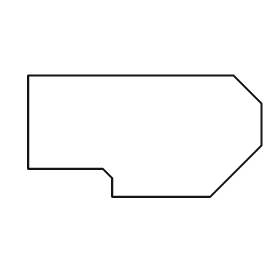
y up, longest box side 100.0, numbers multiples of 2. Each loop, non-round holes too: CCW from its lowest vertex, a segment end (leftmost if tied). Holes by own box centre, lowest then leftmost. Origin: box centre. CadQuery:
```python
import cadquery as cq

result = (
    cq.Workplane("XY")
    .moveTo(-14.0, -26.0)
    .lineTo(28.0, -26.0)
    .lineTo(50.0, -4.0)
    .lineTo(50.0, 14.0)
    .lineTo(38.0, 26.0)
    .lineTo(-50.0, 26.0)
    .lineTo(-50.0, -14.0)
    .lineTo(-18.0, -14.0)
    .lineTo(-14.0, -18.0)
    .close()
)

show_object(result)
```